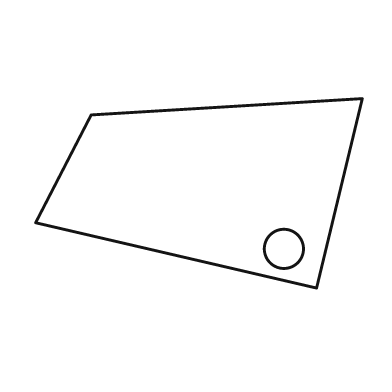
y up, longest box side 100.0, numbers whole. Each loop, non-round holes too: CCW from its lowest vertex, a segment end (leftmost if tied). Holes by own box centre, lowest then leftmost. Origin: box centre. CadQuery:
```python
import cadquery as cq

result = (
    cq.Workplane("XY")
    .moveTo(36.0, -29.0)
    .lineTo(50.0, 29.0)
    .lineTo(-33.0, 24.0)
    .lineTo(-50.0, -9.0)
    .close()
    .moveTo(26.0, -17.0)
    .circle(6.0)
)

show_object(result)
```